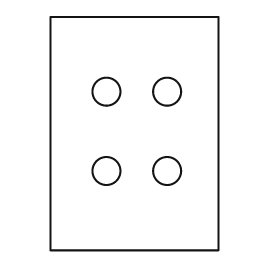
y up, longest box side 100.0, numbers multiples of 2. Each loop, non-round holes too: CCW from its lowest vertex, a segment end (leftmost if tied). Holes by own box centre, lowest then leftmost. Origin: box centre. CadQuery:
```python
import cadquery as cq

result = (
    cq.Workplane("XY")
    .moveTo(-36.0, -50.0)
    .lineTo(36.0, -50.0)
    .lineTo(36.0, 50.0)
    .lineTo(-36.0, 50.0)
    .close()
    .moveTo(-12.0, -16.0)
    .circle(6.0)
    .moveTo(14.0, -16.0)
    .circle(6.0)
    .moveTo(-12.0, 18.0)
    .circle(6.0)
    .moveTo(14.0, 18.0)
    .circle(6.0)
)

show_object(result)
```